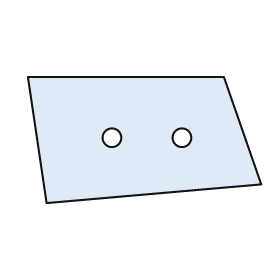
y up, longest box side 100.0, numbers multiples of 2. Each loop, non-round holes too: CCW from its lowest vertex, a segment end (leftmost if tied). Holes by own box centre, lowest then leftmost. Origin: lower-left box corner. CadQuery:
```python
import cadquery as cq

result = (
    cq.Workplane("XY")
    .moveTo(8.0, 0.0)
    .lineTo(100.0, 8.0)
    .lineTo(84.0, 54.0)
    .lineTo(0.0, 54.0)
    .close()
    .moveTo(36.0, 28.0)
    .circle(4.0)
    .moveTo(66.0, 28.0)
    .circle(4.0)
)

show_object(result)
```